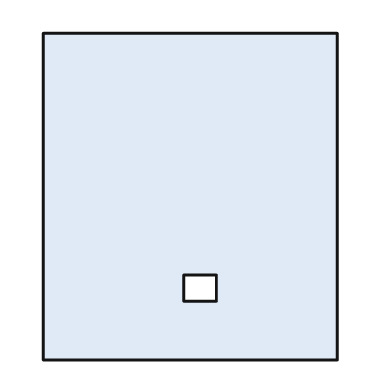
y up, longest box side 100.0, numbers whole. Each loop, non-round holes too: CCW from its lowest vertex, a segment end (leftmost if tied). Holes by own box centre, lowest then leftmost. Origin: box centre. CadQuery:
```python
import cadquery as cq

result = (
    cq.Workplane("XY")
    .moveTo(-45.0, -50.0)
    .lineTo(45.0, -50.0)
    .lineTo(45.0, 50.0)
    .lineTo(-45.0, 50.0)
    .close()
    .moveTo(-2.0, -32.0)
    .lineTo(8.0, -32.0)
    .lineTo(8.0, -24.0)
    .lineTo(-2.0, -24.0)
    .close()
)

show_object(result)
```